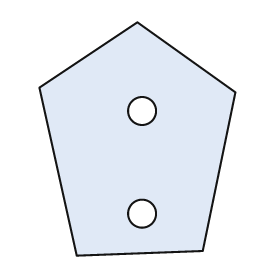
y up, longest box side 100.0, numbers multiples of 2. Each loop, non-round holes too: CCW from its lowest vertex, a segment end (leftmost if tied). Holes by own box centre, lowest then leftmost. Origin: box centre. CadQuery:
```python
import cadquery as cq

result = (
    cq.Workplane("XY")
    .moveTo(-26.0, -50.0)
    .lineTo(28.0, -48.0)
    .lineTo(42.0, 20.0)
    .lineTo(0.0, 50.0)
    .lineTo(-42.0, 22.0)
    .close()
    .moveTo(2.0, -32.0)
    .circle(6.0)
    .moveTo(2.0, 12.0)
    .circle(6.0)
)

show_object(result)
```